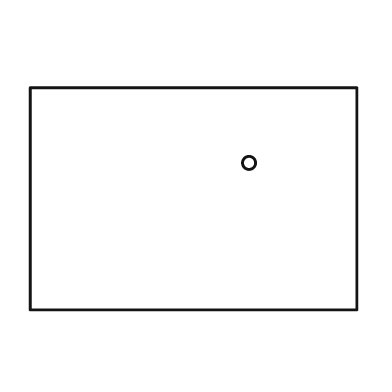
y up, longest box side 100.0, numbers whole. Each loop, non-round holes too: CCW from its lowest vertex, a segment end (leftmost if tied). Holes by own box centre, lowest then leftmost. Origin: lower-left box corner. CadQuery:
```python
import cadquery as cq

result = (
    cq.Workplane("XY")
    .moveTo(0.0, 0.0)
    .lineTo(100.0, 0.0)
    .lineTo(100.0, 68.0)
    .lineTo(0.0, 68.0)
    .close()
    .moveTo(67.0, 45.0)
    .circle(2.0)
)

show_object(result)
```